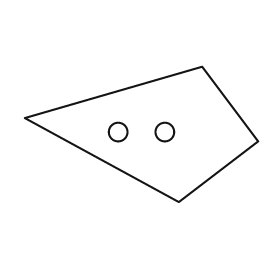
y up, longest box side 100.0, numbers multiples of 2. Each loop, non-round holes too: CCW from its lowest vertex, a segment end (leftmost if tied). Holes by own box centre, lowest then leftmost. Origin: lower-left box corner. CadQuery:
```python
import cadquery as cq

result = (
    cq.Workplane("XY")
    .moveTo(66.0, 0.0)
    .lineTo(100.0, 26.0)
    .lineTo(76.0, 58.0)
    .lineTo(0.0, 36.0)
    .close()
    .moveTo(40.0, 30.0)
    .circle(4.0)
    .moveTo(60.0, 30.0)
    .circle(4.0)
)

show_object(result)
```